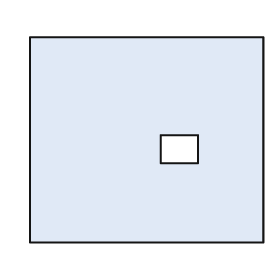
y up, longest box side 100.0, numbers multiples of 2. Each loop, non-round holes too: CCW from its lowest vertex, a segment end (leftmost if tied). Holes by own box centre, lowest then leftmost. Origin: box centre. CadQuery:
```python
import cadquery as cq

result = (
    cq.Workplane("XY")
    .moveTo(-50.0, -44.0)
    .lineTo(50.0, -44.0)
    .lineTo(50.0, 44.0)
    .lineTo(-50.0, 44.0)
    .close()
    .moveTo(6.0, -10.0)
    .lineTo(22.0, -10.0)
    .lineTo(22.0, 2.0)
    .lineTo(6.0, 2.0)
    .close()
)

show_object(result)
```